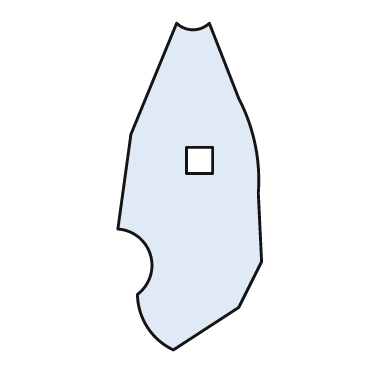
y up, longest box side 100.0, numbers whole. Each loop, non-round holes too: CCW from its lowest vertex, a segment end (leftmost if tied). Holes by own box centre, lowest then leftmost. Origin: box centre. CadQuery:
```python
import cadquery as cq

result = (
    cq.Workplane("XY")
    .moveTo(-5.0, -50.0)
    .lineTo(15.0, -37.0)
    .lineTo(22.0, -23.0)
    .lineTo(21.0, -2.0)
    .threePointArc((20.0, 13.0), (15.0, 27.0))
    .lineTo(6.0, 50.0)
    .threePointArc((1.0, 48.0), (-4.0, 50.0))
    .lineTo(-18.0, 16.0)
    .lineTo(-22.0, -13.0)
    .threePointArc((-12.0, -21.0), (-16.0, -33.0))
    .threePointArc((-13.0, -43.0), (-5.0, -50.0))
    .close()
    .moveTo(-1.0, 4.0)
    .lineTo(7.0, 4.0)
    .lineTo(7.0, 12.0)
    .lineTo(-1.0, 12.0)
    .close()
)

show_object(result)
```